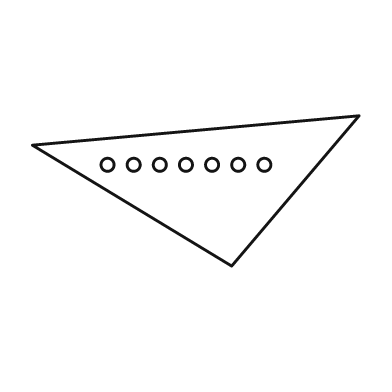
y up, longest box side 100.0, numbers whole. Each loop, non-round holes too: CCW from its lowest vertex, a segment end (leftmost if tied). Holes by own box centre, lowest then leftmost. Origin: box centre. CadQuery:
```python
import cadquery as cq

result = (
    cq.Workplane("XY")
    .moveTo(11.0, -23.0)
    .lineTo(50.0, 23.0)
    .lineTo(-50.0, 14.0)
    .close()
    .moveTo(-27.0, 8.0)
    .circle(2.0)
    .moveTo(-19.0, 8.0)
    .circle(2.0)
    .moveTo(-11.0, 8.0)
    .circle(2.0)
    .moveTo(-3.0, 8.0)
    .circle(2.0)
    .moveTo(5.0, 8.0)
    .circle(2.0)
    .moveTo(13.0, 8.0)
    .circle(2.0)
    .moveTo(21.0, 8.0)
    .circle(2.0)
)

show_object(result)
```